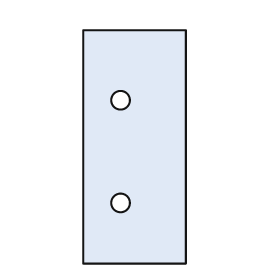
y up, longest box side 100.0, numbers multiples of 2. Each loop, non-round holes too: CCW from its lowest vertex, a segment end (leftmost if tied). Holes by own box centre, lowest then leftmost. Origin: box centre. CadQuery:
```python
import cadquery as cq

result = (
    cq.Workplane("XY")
    .moveTo(-22.0, -50.0)
    .lineTo(22.0, -50.0)
    .lineTo(22.0, 50.0)
    .lineTo(-22.0, 50.0)
    .close()
    .moveTo(-6.0, -24.0)
    .circle(4.0)
    .moveTo(-6.0, 20.0)
    .circle(4.0)
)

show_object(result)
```